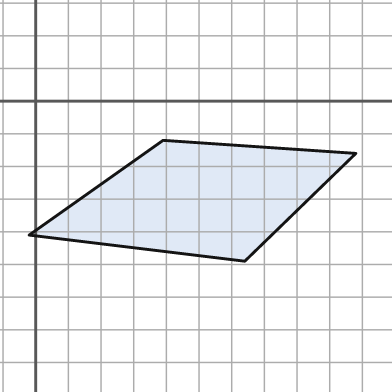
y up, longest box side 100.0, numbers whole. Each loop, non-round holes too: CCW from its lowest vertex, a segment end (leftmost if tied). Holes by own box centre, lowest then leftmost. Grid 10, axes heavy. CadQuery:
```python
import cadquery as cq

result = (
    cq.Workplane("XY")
    .moveTo(64.0, -49.0)
    .lineTo(98.0, -16.0)
    .lineTo(39.0, -12.0)
    .lineTo(-2.0, -41.0)
    .close()
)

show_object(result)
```